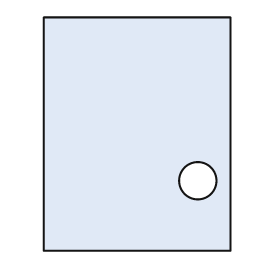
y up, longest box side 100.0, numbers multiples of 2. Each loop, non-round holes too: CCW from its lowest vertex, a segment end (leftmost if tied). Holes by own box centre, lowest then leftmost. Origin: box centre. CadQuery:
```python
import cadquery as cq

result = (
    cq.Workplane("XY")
    .moveTo(-40.0, -50.0)
    .lineTo(40.0, -50.0)
    .lineTo(40.0, 50.0)
    .lineTo(-40.0, 50.0)
    .close()
    .moveTo(26.0, -20.0)
    .circle(8.0)
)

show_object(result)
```